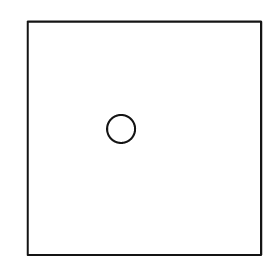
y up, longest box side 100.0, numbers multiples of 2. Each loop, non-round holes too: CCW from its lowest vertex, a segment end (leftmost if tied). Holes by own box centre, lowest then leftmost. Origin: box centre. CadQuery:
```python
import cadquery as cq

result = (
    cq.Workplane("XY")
    .moveTo(-50.0, -50.0)
    .lineTo(50.0, -50.0)
    .lineTo(50.0, 50.0)
    .lineTo(-50.0, 50.0)
    .close()
    .moveTo(-10.0, 4.0)
    .circle(6.0)
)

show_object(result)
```